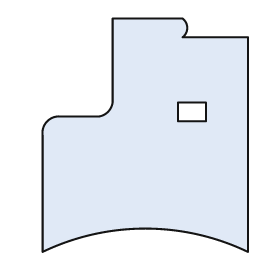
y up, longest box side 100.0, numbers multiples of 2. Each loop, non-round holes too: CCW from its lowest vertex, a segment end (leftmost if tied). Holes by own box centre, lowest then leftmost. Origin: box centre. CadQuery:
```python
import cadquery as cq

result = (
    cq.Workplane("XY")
    .moveTo(-44.0, -50.0)
    .threePointArc((0.0, -40.0), (44.0, -50.0))
    .lineTo(44.0, 42.0)
    .lineTo(16.0, 42.0)
    .threePointArc((18.0, 46.0), (16.0, 50.0))
    .lineTo(-14.0, 50.0)
    .lineTo(-14.0, 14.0)
    .threePointArc((-16.0, 10.0), (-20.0, 8.0))
    .lineTo(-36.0, 8.0)
    .threePointArc((-42.0, 6.0), (-44.0, 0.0))
    .close()
    .moveTo(14.0, 6.0)
    .lineTo(26.0, 6.0)
    .lineTo(26.0, 14.0)
    .lineTo(14.0, 14.0)
    .close()
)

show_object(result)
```